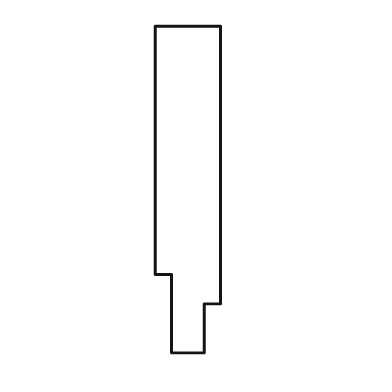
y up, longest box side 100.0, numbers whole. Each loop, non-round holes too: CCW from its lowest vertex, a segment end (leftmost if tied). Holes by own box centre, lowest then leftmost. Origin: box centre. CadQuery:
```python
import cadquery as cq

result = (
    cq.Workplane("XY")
    .moveTo(-5.0, -50.0)
    .lineTo(5.0, -50.0)
    .lineTo(5.0, -35.0)
    .lineTo(10.0, -35.0)
    .lineTo(10.0, 50.0)
    .lineTo(-10.0, 50.0)
    .lineTo(-10.0, -26.0)
    .lineTo(-5.0, -26.0)
    .close()
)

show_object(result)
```